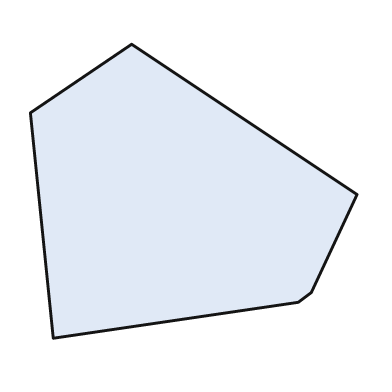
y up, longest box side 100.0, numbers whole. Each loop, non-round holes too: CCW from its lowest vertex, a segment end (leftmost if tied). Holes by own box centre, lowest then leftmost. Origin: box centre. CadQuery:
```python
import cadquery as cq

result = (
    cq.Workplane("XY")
    .moveTo(-43.0, -45.0)
    .lineTo(32.0, -34.0)
    .lineTo(36.0, -31.0)
    .lineTo(50.0, -1.0)
    .lineTo(-19.0, 45.0)
    .lineTo(-50.0, 24.0)
    .close()
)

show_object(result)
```